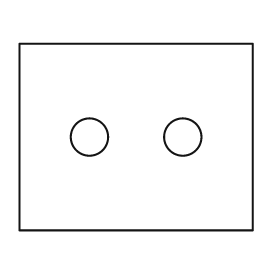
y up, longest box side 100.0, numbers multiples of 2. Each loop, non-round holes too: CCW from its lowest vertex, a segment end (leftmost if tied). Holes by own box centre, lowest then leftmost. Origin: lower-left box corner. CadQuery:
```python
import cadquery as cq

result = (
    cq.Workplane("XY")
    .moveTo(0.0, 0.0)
    .lineTo(100.0, 0.0)
    .lineTo(100.0, 80.0)
    .lineTo(0.0, 80.0)
    .close()
    .moveTo(30.0, 40.0)
    .circle(8.0)
    .moveTo(70.0, 40.0)
    .circle(8.0)
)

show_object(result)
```